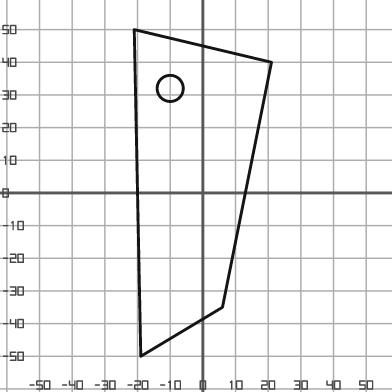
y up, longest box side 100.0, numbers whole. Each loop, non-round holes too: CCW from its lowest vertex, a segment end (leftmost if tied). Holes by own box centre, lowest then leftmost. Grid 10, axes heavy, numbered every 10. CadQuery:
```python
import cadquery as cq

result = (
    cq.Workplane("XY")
    .moveTo(-19.0, -50.0)
    .lineTo(6.0, -35.0)
    .lineTo(21.0, 40.0)
    .lineTo(-21.0, 50.0)
    .close()
    .moveTo(-10.0, 32.0)
    .circle(4.0)
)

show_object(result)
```